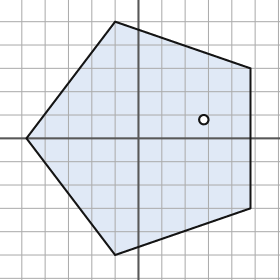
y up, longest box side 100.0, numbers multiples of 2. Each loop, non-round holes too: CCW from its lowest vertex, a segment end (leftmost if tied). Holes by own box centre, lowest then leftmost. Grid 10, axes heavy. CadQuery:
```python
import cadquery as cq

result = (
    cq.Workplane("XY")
    .moveTo(-10.0, -50.0)
    .lineTo(48.0, -30.0)
    .lineTo(48.0, 30.0)
    .lineTo(-10.0, 50.0)
    .lineTo(-48.0, 0.0)
    .close()
    .moveTo(28.0, 8.0)
    .circle(2.0)
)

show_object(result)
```